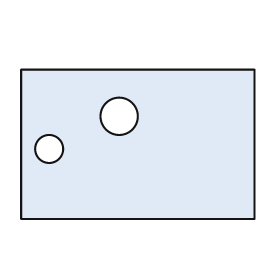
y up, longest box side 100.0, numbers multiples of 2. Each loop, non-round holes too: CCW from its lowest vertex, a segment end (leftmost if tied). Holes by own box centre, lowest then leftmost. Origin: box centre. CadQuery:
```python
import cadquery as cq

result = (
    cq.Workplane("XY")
    .moveTo(-50.0, -32.0)
    .lineTo(50.0, -32.0)
    .lineTo(50.0, 32.0)
    .lineTo(-50.0, 32.0)
    .close()
    .moveTo(-38.0, -2.0)
    .circle(6.0)
    .moveTo(-8.0, 12.0)
    .circle(8.0)
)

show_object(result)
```